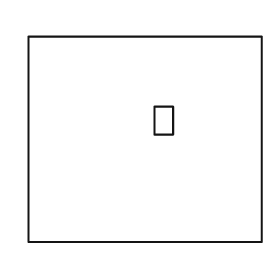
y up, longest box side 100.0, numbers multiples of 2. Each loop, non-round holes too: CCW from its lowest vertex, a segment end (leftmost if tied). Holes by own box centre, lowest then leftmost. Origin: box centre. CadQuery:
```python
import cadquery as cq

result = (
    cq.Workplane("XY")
    .moveTo(-50.0, -44.0)
    .lineTo(50.0, -44.0)
    .lineTo(50.0, 44.0)
    .lineTo(-50.0, 44.0)
    .close()
    .moveTo(4.0, 2.0)
    .lineTo(12.0, 2.0)
    .lineTo(12.0, 14.0)
    .lineTo(4.0, 14.0)
    .close()
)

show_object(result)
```